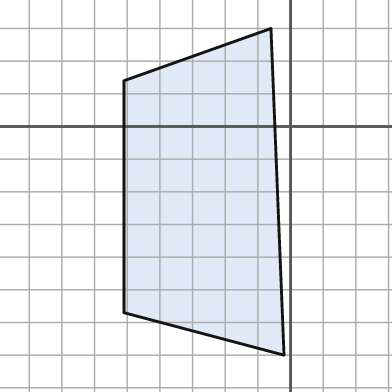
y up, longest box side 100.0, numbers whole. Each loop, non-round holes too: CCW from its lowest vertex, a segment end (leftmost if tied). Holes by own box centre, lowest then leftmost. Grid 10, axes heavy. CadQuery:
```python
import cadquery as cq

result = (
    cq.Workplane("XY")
    .moveTo(-2.0, -70.0)
    .lineTo(-6.0, 30.0)
    .lineTo(-51.0, 14.0)
    .lineTo(-51.0, -57.0)
    .close()
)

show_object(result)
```